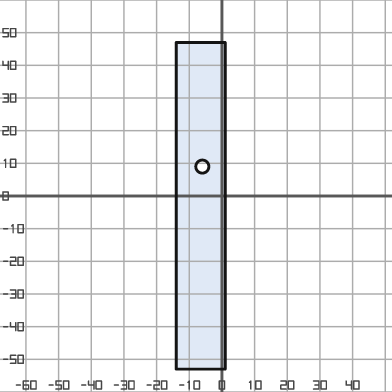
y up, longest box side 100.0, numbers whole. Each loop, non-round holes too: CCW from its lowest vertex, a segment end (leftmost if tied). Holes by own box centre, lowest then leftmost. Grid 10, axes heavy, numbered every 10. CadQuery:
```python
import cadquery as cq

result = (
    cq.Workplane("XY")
    .moveTo(-14.0, -53.0)
    .lineTo(1.0, -53.0)
    .lineTo(1.0, 47.0)
    .lineTo(-14.0, 47.0)
    .close()
    .moveTo(-6.0, 9.0)
    .circle(2.0)
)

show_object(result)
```